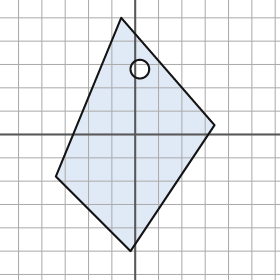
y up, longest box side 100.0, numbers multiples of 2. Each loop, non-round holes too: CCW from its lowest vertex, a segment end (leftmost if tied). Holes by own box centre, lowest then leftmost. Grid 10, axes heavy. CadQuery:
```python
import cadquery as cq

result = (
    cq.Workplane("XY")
    .moveTo(-2.0, -50.0)
    .lineTo(34.0, 4.0)
    .lineTo(-6.0, 50.0)
    .lineTo(-34.0, -18.0)
    .close()
    .moveTo(2.0, 28.0)
    .circle(4.0)
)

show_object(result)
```